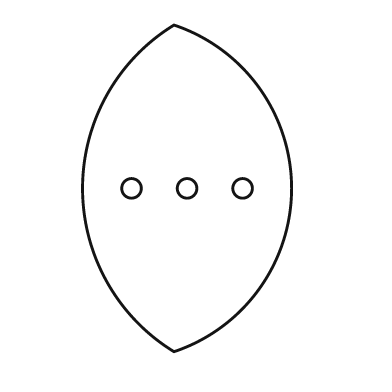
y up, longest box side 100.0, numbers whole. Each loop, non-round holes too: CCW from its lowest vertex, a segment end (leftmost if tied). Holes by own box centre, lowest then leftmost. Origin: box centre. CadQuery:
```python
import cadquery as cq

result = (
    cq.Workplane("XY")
    .moveTo(-4.0, -50.0)
    .threePointArc((32.0, 0.0), (-4.0, 50.0))
    .threePointArc((-32.0, 0.0), (-4.0, -50.0))
    .close()
    .moveTo(-17.0, 0.0)
    .circle(3.0)
    .moveTo(0.0, 0.0)
    .circle(3.0)
    .moveTo(17.0, 0.0)
    .circle(3.0)
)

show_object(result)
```